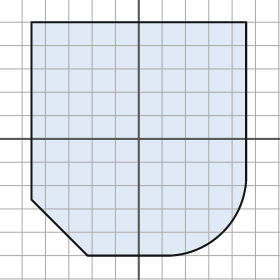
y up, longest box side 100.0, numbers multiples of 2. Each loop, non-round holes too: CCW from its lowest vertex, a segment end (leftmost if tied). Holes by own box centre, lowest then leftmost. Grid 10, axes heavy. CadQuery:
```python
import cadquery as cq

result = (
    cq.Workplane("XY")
    .moveTo(-22.0, -50.0)
    .lineTo(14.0, -50.0)
    .threePointArc((36.0, -40.0), (46.0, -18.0))
    .lineTo(46.0, 50.0)
    .lineTo(-46.0, 50.0)
    .lineTo(-46.0, -26.0)
    .close()
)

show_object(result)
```